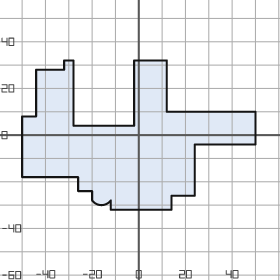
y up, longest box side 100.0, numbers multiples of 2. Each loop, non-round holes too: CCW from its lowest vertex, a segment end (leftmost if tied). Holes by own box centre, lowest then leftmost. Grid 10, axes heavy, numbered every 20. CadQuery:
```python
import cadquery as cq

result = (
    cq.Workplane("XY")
    .moveTo(-12.0, -32.0)
    .lineTo(14.0, -32.0)
    .lineTo(14.0, -26.0)
    .lineTo(24.0, -26.0)
    .lineTo(24.0, -4.0)
    .lineTo(50.0, -4.0)
    .lineTo(50.0, 10.0)
    .lineTo(12.0, 10.0)
    .lineTo(12.0, 32.0)
    .lineTo(-2.0, 32.0)
    .lineTo(-2.0, 4.0)
    .lineTo(-28.0, 4.0)
    .lineTo(-28.0, 32.0)
    .lineTo(-32.0, 32.0)
    .lineTo(-32.0, 28.0)
    .lineTo(-44.0, 28.0)
    .lineTo(-44.0, 8.0)
    .lineTo(-50.0, 8.0)
    .lineTo(-50.0, -18.0)
    .lineTo(-26.0, -18.0)
    .lineTo(-26.0, -24.0)
    .lineTo(-20.0, -24.0)
    .lineTo(-20.0, -28.0)
    .threePointArc((-16.0, -30.0), (-12.0, -28.0))
    .close()
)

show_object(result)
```